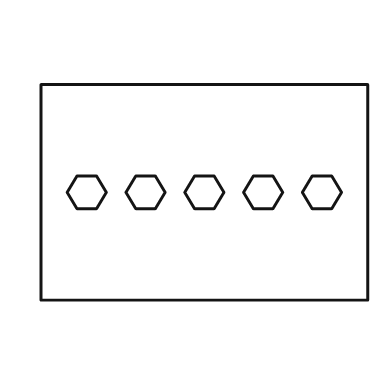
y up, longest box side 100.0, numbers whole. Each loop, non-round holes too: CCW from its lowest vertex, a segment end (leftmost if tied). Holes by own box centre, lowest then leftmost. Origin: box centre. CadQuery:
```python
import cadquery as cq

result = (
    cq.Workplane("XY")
    .moveTo(-50.0, -33.0)
    .lineTo(50.0, -33.0)
    .lineTo(50.0, 33.0)
    .lineTo(-50.0, 33.0)
    .close()
    .moveTo(-39.0, -5.0)
    .lineTo(-33.0, -5.0)
    .lineTo(-30.0, 0.0)
    .lineTo(-33.0, 5.0)
    .lineTo(-39.0, 5.0)
    .lineTo(-42.0, 0.0)
    .close()
    .moveTo(-21.0, -5.0)
    .lineTo(-15.0, -5.0)
    .lineTo(-12.0, 0.0)
    .lineTo(-15.0, 5.0)
    .lineTo(-21.0, 5.0)
    .lineTo(-24.0, 0.0)
    .close()
    .moveTo(-3.0, -5.0)
    .lineTo(3.0, -5.0)
    .lineTo(6.0, 0.0)
    .lineTo(3.0, 5.0)
    .lineTo(-3.0, 5.0)
    .lineTo(-6.0, 0.0)
    .close()
    .moveTo(15.0, -5.0)
    .lineTo(21.0, -5.0)
    .lineTo(24.0, 0.0)
    .lineTo(21.0, 5.0)
    .lineTo(15.0, 5.0)
    .lineTo(12.0, 0.0)
    .close()
    .moveTo(33.0, -5.0)
    .lineTo(39.0, -5.0)
    .lineTo(42.0, 0.0)
    .lineTo(39.0, 5.0)
    .lineTo(33.0, 5.0)
    .lineTo(30.0, 0.0)
    .close()
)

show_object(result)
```